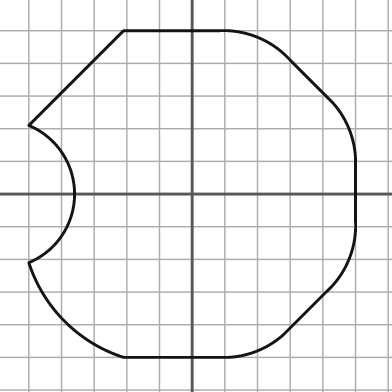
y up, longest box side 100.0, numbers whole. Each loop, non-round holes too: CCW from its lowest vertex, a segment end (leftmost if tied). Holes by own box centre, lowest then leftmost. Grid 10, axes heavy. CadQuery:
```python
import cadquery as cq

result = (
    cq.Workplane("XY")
    .moveTo(-21.0, -50.0)
    .lineTo(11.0, -50.0)
    .threePointArc((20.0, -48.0), (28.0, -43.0))
    .lineTo(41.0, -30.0)
    .threePointArc((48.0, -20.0), (50.0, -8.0))
    .lineTo(50.0, 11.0)
    .threePointArc((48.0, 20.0), (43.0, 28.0))
    .lineTo(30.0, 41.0)
    .threePointArc((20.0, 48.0), (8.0, 50.0))
    .lineTo(-21.0, 50.0)
    .lineTo(-50.0, 21.0)
    .threePointArc((-36.0, 0.0), (-50.0, -21.0))
    .threePointArc((-39.0, -39.0), (-21.0, -50.0))
    .close()
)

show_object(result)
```